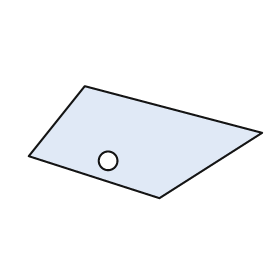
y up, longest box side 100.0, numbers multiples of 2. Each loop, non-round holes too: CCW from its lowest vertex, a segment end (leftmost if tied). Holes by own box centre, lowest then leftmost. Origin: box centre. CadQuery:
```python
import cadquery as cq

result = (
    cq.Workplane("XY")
    .moveTo(6.0, -24.0)
    .lineTo(50.0, 4.0)
    .lineTo(-26.0, 24.0)
    .lineTo(-50.0, -6.0)
    .close()
    .moveTo(-16.0, -8.0)
    .circle(4.0)
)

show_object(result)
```